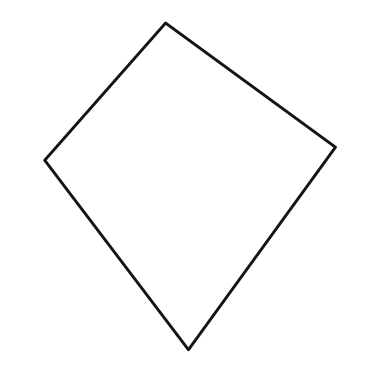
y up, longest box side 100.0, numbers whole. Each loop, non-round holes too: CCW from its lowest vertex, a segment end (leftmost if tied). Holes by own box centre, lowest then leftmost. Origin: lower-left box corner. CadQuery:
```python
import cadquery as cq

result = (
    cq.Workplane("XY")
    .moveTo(44.0, 0.0)
    .lineTo(89.0, 62.0)
    .lineTo(37.0, 100.0)
    .lineTo(0.0, 58.0)
    .close()
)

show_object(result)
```